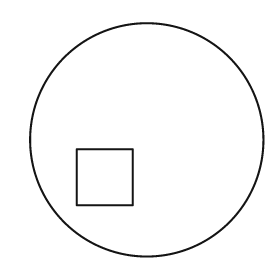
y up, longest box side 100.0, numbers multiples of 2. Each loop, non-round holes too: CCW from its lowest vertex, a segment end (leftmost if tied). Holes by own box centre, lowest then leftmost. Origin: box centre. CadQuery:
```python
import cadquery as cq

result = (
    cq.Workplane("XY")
    .moveTo(0.0, 0.0)
    .circle(50.0)
    .moveTo(-30.0, -28.0)
    .lineTo(-6.0, -28.0)
    .lineTo(-6.0, -4.0)
    .lineTo(-30.0, -4.0)
    .close()
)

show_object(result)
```